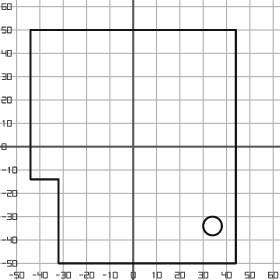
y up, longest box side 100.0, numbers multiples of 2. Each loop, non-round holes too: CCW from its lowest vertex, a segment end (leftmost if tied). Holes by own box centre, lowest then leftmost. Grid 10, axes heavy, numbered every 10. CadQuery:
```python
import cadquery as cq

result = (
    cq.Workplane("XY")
    .moveTo(-32.0, -50.0)
    .lineTo(44.0, -50.0)
    .lineTo(44.0, 50.0)
    .lineTo(-44.0, 50.0)
    .lineTo(-44.0, -14.0)
    .lineTo(-32.0, -14.0)
    .close()
    .moveTo(34.0, -34.0)
    .circle(4.0)
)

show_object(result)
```